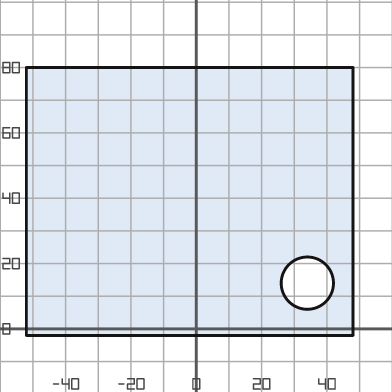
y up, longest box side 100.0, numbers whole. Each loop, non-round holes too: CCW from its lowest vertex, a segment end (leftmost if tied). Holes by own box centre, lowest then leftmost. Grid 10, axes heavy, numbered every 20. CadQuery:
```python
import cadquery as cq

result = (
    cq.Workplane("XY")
    .moveTo(-52.0, -2.0)
    .lineTo(48.0, -2.0)
    .lineTo(48.0, 80.0)
    .lineTo(-52.0, 80.0)
    .close()
    .moveTo(34.0, 14.0)
    .circle(8.0)
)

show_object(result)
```